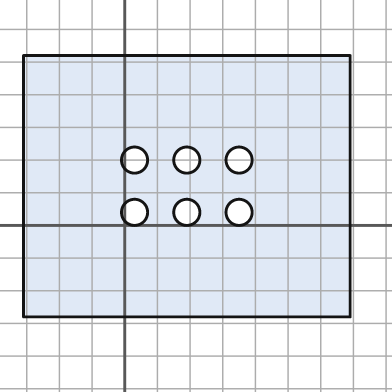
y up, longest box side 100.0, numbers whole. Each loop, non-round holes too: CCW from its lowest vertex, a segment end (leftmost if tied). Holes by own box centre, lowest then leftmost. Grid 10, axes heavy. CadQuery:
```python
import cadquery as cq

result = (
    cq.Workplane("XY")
    .moveTo(-31.0, -28.0)
    .lineTo(69.0, -28.0)
    .lineTo(69.0, 52.0)
    .lineTo(-31.0, 52.0)
    .close()
    .moveTo(3.0, 4.0)
    .circle(4.0)
    .moveTo(19.0, 4.0)
    .circle(4.0)
    .moveTo(35.0, 4.0)
    .circle(4.0)
    .moveTo(3.0, 20.0)
    .circle(4.0)
    .moveTo(19.0, 20.0)
    .circle(4.0)
    .moveTo(35.0, 20.0)
    .circle(4.0)
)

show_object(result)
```